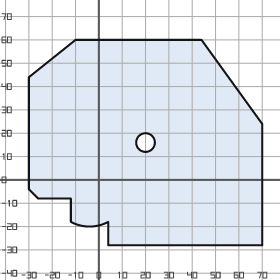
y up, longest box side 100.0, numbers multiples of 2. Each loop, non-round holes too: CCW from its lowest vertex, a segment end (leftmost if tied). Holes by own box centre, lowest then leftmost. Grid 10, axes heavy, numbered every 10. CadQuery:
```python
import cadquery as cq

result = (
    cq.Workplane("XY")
    .moveTo(4.0, -28.0)
    .lineTo(70.0, -28.0)
    .lineTo(70.0, 24.0)
    .lineTo(44.0, 60.0)
    .lineTo(-10.0, 60.0)
    .lineTo(-30.0, 44.0)
    .lineTo(-30.0, -4.0)
    .lineTo(-26.0, -8.0)
    .lineTo(-12.0, -8.0)
    .lineTo(-12.0, -18.0)
    .threePointArc((-4.0, -20.0), (4.0, -18.0))
    .close()
    .moveTo(20.0, 16.0)
    .circle(4.0)
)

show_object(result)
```